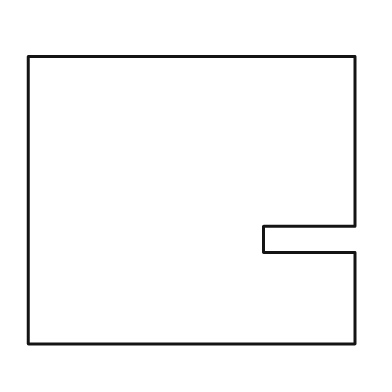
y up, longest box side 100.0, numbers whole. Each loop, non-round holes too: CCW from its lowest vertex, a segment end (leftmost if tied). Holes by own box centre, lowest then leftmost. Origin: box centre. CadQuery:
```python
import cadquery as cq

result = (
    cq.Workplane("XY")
    .moveTo(-50.0, -44.0)
    .lineTo(50.0, -44.0)
    .lineTo(50.0, -16.0)
    .lineTo(22.0, -16.0)
    .lineTo(22.0, -8.0)
    .lineTo(50.0, -8.0)
    .lineTo(50.0, 44.0)
    .lineTo(-50.0, 44.0)
    .close()
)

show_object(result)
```